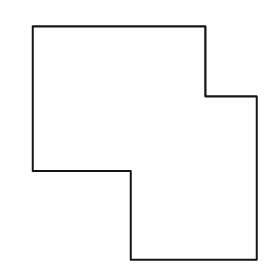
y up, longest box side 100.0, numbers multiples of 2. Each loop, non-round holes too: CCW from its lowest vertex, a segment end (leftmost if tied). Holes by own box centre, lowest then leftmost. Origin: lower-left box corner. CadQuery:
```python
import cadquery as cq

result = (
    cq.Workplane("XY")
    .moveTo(42.0, 0.0)
    .lineTo(96.0, 0.0)
    .lineTo(96.0, 70.0)
    .lineTo(74.0, 70.0)
    .lineTo(74.0, 100.0)
    .lineTo(0.0, 100.0)
    .lineTo(0.0, 38.0)
    .lineTo(42.0, 38.0)
    .close()
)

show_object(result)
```